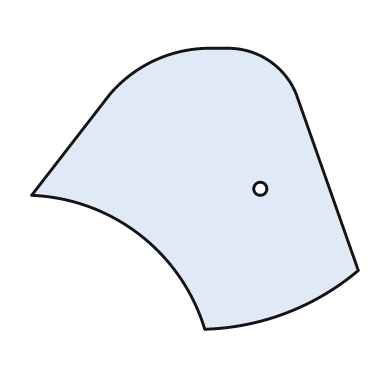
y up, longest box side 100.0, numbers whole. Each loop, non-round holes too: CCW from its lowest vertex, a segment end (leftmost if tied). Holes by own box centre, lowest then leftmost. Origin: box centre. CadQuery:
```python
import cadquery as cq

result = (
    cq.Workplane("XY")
    .moveTo(3.0, -43.0)
    .threePointArc((28.0, -38.0), (50.0, -25.0))
    .lineTo(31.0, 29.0)
    .threePointArc((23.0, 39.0), (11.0, 43.0))
    .lineTo(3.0, 43.0)
    .threePointArc((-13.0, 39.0), (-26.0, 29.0))
    .lineTo(-50.0, -2.0)
    .threePointArc((-17.0, -14.0), (3.0, -43.0))
    .close()
    .moveTo(20.0, 0.0)
    .circle(2.0)
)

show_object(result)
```